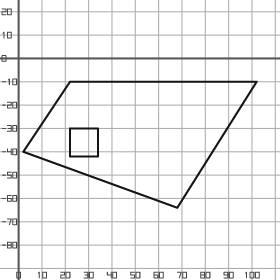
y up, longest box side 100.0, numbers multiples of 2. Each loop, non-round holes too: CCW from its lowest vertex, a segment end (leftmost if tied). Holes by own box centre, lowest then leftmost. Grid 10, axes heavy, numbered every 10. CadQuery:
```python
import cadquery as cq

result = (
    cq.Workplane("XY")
    .moveTo(68.0, -64.0)
    .lineTo(102.0, -10.0)
    .lineTo(22.0, -10.0)
    .lineTo(2.0, -40.0)
    .close()
    .moveTo(22.0, -42.0)
    .lineTo(34.0, -42.0)
    .lineTo(34.0, -30.0)
    .lineTo(22.0, -30.0)
    .close()
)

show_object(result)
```